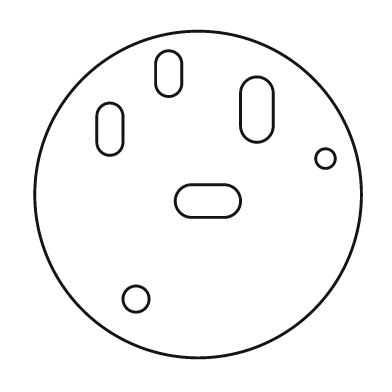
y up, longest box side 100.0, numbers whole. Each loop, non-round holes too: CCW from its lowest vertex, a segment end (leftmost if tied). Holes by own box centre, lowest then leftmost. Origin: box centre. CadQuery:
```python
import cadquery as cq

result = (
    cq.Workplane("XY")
    .moveTo(0.0, 0.0)
    .circle(50.0)
    .moveTo(-19.0, -32.0)
    .circle(4.0)
    .moveTo(-2.0, -7.0)
    .lineTo(8.0, -7.0)
    .threePointArc((13.0, -2.0), (8.0, 3.0))
    .lineTo(-2.0, 3.0)
    .threePointArc((-7.0, -2.0), (-2.0, -7.0))
    .close()
    .moveTo(39.0, 11.0)
    .circle(3.0)
    .moveTo(-31.0, 16.0)
    .threePointArc((-27.0, 12.0), (-23.0, 16.0))
    .lineTo(-23.0, 24.0)
    .threePointArc((-27.0, 28.0), (-31.0, 24.0))
    .close()
    .moveTo(13.0, 21.0)
    .threePointArc((18.0, 16.0), (23.0, 21.0))
    .lineTo(23.0, 31.0)
    .threePointArc((18.0, 36.0), (13.0, 31.0))
    .close()
    .moveTo(-13.0, 34.0)
    .threePointArc((-9.0, 30.0), (-5.0, 34.0))
    .lineTo(-5.0, 40.0)
    .threePointArc((-9.0, 44.0), (-13.0, 40.0))
    .close()
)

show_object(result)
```